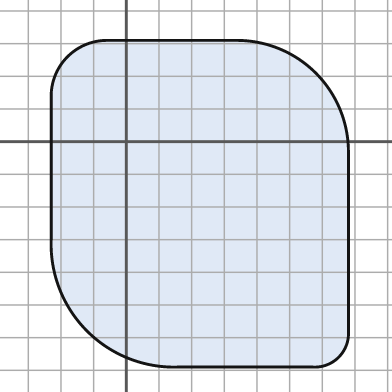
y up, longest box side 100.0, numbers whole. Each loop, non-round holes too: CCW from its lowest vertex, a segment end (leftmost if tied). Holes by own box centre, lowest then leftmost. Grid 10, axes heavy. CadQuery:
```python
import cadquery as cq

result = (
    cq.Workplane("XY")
    .moveTo(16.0, -69.0)
    .lineTo(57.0, -69.0)
    .threePointArc((65.0, -66.0), (68.0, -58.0))
    .lineTo(68.0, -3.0)
    .threePointArc((58.0, 21.0), (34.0, 31.0))
    .lineTo(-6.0, 31.0)
    .threePointArc((-18.0, 26.0), (-23.0, 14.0))
    .lineTo(-23.0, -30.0)
    .threePointArc((-12.0, -58.0), (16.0, -69.0))
    .close()
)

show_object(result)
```